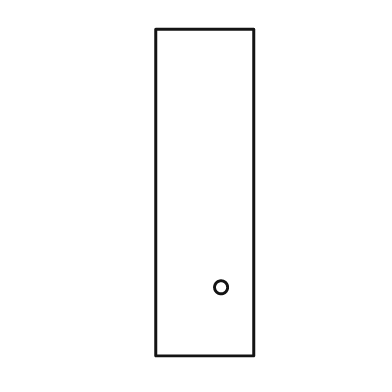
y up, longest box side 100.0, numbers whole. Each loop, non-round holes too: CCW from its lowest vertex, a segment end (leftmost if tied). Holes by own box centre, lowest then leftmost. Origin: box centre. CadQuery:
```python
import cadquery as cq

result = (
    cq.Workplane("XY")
    .moveTo(-15.0, -50.0)
    .lineTo(15.0, -50.0)
    .lineTo(15.0, 50.0)
    .lineTo(-15.0, 50.0)
    .close()
    .moveTo(5.0, -29.0)
    .circle(2.0)
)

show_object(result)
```